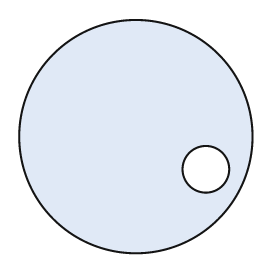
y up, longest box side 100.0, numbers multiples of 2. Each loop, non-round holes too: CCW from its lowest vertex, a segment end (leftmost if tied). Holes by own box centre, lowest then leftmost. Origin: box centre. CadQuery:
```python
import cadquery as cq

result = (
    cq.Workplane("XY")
    .moveTo(0.0, 0.0)
    .circle(50.0)
    .moveTo(30.0, -14.0)
    .circle(10.0)
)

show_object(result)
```